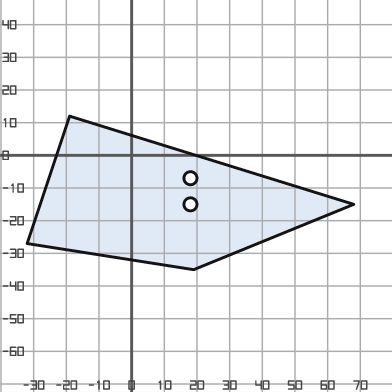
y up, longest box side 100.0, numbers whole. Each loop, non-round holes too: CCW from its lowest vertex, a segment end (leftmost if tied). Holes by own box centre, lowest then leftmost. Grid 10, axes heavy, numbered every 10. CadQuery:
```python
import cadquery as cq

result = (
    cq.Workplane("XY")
    .moveTo(19.0, -35.0)
    .lineTo(68.0, -15.0)
    .lineTo(-19.0, 12.0)
    .lineTo(-32.0, -27.0)
    .close()
    .moveTo(18.0, -15.0)
    .circle(2.0)
    .moveTo(18.0, -7.0)
    .circle(2.0)
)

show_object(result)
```